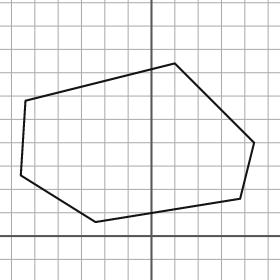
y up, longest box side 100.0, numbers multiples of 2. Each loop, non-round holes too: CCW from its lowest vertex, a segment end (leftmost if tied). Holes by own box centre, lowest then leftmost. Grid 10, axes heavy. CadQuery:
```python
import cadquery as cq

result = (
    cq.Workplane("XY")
    .moveTo(-24.0, 6.0)
    .lineTo(38.0, 16.0)
    .lineTo(44.0, 40.0)
    .lineTo(10.0, 74.0)
    .lineTo(-54.0, 58.0)
    .lineTo(-56.0, 26.0)
    .close()
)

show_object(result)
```